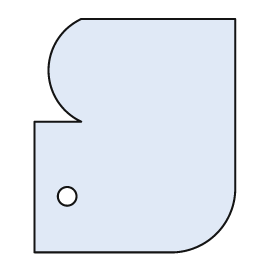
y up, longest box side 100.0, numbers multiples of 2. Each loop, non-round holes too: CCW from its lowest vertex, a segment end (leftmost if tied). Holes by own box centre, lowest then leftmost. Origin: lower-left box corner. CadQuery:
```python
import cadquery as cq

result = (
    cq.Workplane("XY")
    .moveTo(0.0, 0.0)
    .lineTo(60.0, 0.0)
    .threePointArc((78.0, 8.0), (86.0, 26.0))
    .lineTo(86.0, 100.0)
    .lineTo(20.0, 100.0)
    .threePointArc((6.0, 78.0), (20.0, 56.0))
    .lineTo(0.0, 56.0)
    .close()
    .moveTo(14.0, 24.0)
    .circle(4.0)
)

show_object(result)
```